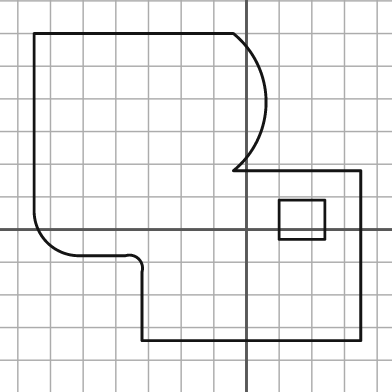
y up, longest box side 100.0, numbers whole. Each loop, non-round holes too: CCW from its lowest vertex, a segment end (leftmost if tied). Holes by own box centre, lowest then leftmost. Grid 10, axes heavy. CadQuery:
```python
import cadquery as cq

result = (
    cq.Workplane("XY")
    .moveTo(-32.0, -34.0)
    .lineTo(35.0, -34.0)
    .lineTo(35.0, 18.0)
    .lineTo(-4.0, 18.0)
    .threePointArc((6.0, 39.0), (-4.0, 60.0))
    .lineTo(-65.0, 60.0)
    .lineTo(-65.0, 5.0)
    .threePointArc((-61.0, -4.0), (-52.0, -8.0))
    .lineTo(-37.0, -8.0)
    .threePointArc((-33.0, -9.0), (-32.0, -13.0))
    .close()
    .moveTo(10.0, -3.0)
    .lineTo(24.0, -3.0)
    .lineTo(24.0, 9.0)
    .lineTo(10.0, 9.0)
    .close()
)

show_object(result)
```